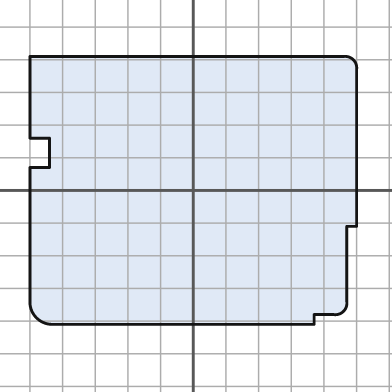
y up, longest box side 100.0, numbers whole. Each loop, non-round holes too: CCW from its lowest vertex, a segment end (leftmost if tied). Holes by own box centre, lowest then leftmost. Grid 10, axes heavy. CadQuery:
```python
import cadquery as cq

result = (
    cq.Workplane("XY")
    .moveTo(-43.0, -41.0)
    .lineTo(37.0, -41.0)
    .lineTo(37.0, -38.0)
    .lineTo(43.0, -38.0)
    .threePointArc((46.0, -37.0), (47.0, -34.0))
    .lineTo(47.0, -11.0)
    .lineTo(50.0, -11.0)
    .lineTo(50.0, 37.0)
    .threePointArc((49.0, 40.0), (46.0, 41.0))
    .lineTo(-50.0, 41.0)
    .lineTo(-50.0, 16.0)
    .lineTo(-44.0, 16.0)
    .lineTo(-44.0, 7.0)
    .lineTo(-50.0, 7.0)
    .lineTo(-50.0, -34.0)
    .threePointArc((-48.0, -39.0), (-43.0, -41.0))
    .close()
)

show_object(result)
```